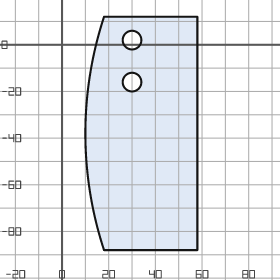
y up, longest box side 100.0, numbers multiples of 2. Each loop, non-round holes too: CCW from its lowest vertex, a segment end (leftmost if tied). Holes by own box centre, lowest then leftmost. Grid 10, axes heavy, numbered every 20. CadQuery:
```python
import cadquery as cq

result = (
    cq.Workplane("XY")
    .moveTo(18.0, -88.0)
    .lineTo(58.0, -88.0)
    .lineTo(58.0, 12.0)
    .lineTo(18.0, 12.0)
    .threePointArc((10.0, -38.0), (18.0, -88.0))
    .close()
    .moveTo(30.0, -16.0)
    .circle(4.0)
    .moveTo(30.0, 2.0)
    .circle(4.0)
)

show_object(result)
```